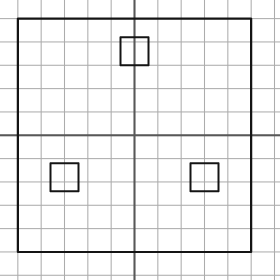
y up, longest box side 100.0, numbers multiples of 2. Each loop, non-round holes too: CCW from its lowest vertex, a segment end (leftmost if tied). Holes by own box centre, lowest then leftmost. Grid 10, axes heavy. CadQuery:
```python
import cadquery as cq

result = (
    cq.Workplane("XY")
    .moveTo(-50.0, -50.0)
    .lineTo(50.0, -50.0)
    .lineTo(50.0, 50.0)
    .lineTo(-50.0, 50.0)
    .close()
    .moveTo(-36.0, -24.0)
    .lineTo(-24.0, -24.0)
    .lineTo(-24.0, -12.0)
    .lineTo(-36.0, -12.0)
    .close()
    .moveTo(24.0, -24.0)
    .lineTo(36.0, -24.0)
    .lineTo(36.0, -12.0)
    .lineTo(24.0, -12.0)
    .close()
    .moveTo(-6.0, 30.0)
    .lineTo(6.0, 30.0)
    .lineTo(6.0, 42.0)
    .lineTo(-6.0, 42.0)
    .close()
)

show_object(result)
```